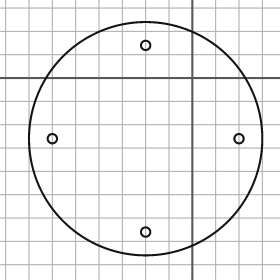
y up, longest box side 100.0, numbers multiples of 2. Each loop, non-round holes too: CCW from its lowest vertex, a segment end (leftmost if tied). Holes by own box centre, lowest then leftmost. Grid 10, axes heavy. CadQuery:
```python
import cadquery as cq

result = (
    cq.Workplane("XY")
    .moveTo(-20.0, -26.0)
    .circle(50.0)
    .moveTo(-20.0, -66.0)
    .circle(2.0)
    .moveTo(-60.0, -26.0)
    .circle(2.0)
    .moveTo(20.0, -26.0)
    .circle(2.0)
    .moveTo(-20.0, 14.0)
    .circle(2.0)
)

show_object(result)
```